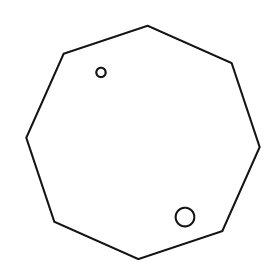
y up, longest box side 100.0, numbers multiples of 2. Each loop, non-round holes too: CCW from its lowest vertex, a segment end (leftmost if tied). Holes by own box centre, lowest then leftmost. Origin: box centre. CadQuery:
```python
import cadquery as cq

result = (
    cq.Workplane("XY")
    .moveTo(-2.0, -50.0)
    .lineTo(34.0, -38.0)
    .lineTo(50.0, -2.0)
    .lineTo(38.0, 34.0)
    .lineTo(2.0, 50.0)
    .lineTo(-34.0, 38.0)
    .lineTo(-50.0, 2.0)
    .lineTo(-38.0, -34.0)
    .close()
    .moveTo(18.0, -32.0)
    .circle(4.0)
    .moveTo(-18.0, 30.0)
    .circle(2.0)
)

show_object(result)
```